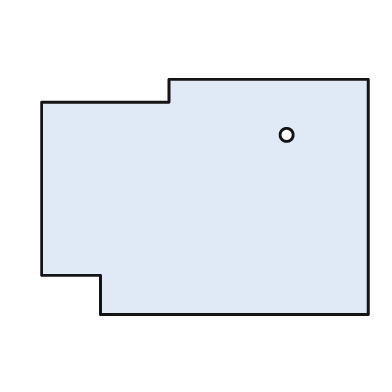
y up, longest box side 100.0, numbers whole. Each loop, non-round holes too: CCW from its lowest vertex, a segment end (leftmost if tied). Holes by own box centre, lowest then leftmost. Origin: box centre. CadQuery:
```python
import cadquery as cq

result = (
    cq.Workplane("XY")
    .moveTo(-32.0, -36.0)
    .lineTo(50.0, -36.0)
    .lineTo(50.0, 36.0)
    .lineTo(-11.0, 36.0)
    .lineTo(-11.0, 29.0)
    .lineTo(-50.0, 29.0)
    .lineTo(-50.0, -24.0)
    .lineTo(-32.0, -24.0)
    .close()
    .moveTo(25.0, 19.0)
    .circle(2.0)
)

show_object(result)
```